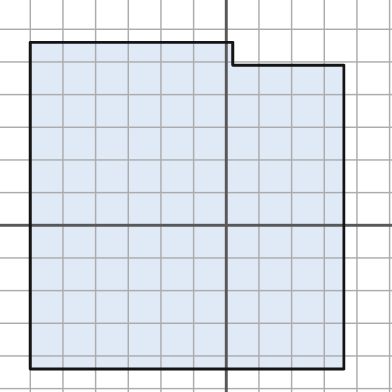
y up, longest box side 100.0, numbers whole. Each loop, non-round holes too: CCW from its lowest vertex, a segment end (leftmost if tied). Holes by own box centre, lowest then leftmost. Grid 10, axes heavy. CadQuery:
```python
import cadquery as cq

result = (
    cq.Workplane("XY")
    .moveTo(-60.0, -44.0)
    .lineTo(36.0, -44.0)
    .lineTo(36.0, 49.0)
    .lineTo(2.0, 49.0)
    .lineTo(2.0, 56.0)
    .lineTo(-60.0, 56.0)
    .close()
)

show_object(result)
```